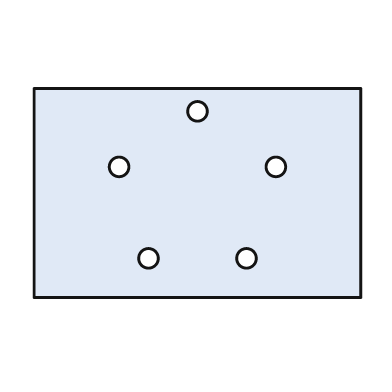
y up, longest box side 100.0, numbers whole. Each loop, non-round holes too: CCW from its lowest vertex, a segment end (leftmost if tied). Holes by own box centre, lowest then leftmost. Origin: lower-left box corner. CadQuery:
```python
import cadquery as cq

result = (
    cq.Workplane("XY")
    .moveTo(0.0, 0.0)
    .lineTo(100.0, 0.0)
    .lineTo(100.0, 64.0)
    .lineTo(0.0, 64.0)
    .close()
    .moveTo(35.0, 12.0)
    .circle(3.0)
    .moveTo(65.0, 12.0)
    .circle(3.0)
    .moveTo(26.0, 40.0)
    .circle(3.0)
    .moveTo(74.0, 40.0)
    .circle(3.0)
    .moveTo(50.0, 57.0)
    .circle(3.0)
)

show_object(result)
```